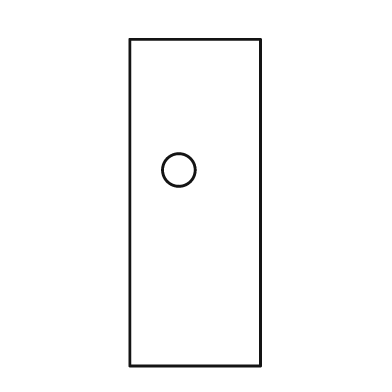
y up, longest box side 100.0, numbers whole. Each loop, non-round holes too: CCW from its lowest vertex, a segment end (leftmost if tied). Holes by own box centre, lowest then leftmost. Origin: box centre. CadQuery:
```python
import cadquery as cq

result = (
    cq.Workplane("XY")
    .moveTo(-20.0, -50.0)
    .lineTo(20.0, -50.0)
    .lineTo(20.0, 50.0)
    .lineTo(-20.0, 50.0)
    .close()
    .moveTo(-5.0, 10.0)
    .circle(5.0)
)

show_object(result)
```